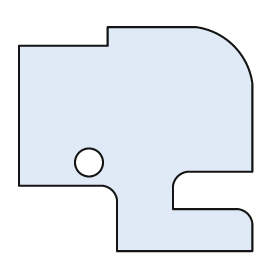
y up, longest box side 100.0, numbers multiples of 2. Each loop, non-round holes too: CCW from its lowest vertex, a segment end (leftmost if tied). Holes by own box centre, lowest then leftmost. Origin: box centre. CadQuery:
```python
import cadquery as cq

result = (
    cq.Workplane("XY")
    .moveTo(-8.0, -48.0)
    .lineTo(50.0, -48.0)
    .lineTo(50.0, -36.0)
    .threePointArc((48.0, -32.0), (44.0, -30.0))
    .lineTo(16.0, -30.0)
    .lineTo(16.0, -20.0)
    .threePointArc((18.0, -16.0), (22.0, -14.0))
    .lineTo(50.0, -14.0)
    .lineTo(50.0, 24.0)
    .threePointArc((42.0, 40.0), (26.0, 48.0))
    .lineTo(-12.0, 48.0)
    .lineTo(-12.0, 40.0)
    .lineTo(-50.0, 40.0)
    .lineTo(-50.0, -20.0)
    .lineTo(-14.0, -20.0)
    .threePointArc((-10.0, -22.0), (-8.0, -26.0))
    .close()
    .moveTo(-20.0, -10.0)
    .circle(6.0)
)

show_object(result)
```